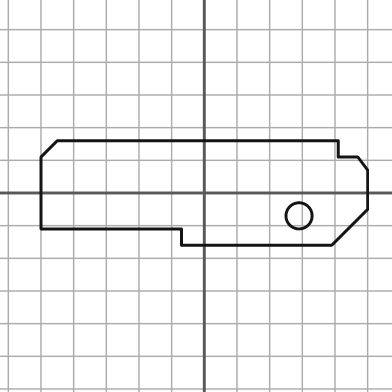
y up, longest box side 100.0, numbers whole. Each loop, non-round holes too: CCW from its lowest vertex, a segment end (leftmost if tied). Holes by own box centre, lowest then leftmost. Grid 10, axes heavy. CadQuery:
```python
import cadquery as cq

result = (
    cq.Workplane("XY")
    .moveTo(-7.0, -16.0)
    .lineTo(39.0, -16.0)
    .lineTo(50.0, -5.0)
    .lineTo(50.0, 7.0)
    .lineTo(47.0, 11.0)
    .lineTo(41.0, 11.0)
    .lineTo(41.0, 16.0)
    .lineTo(-45.0, 16.0)
    .lineTo(-50.0, 11.0)
    .lineTo(-50.0, -11.0)
    .lineTo(-7.0, -11.0)
    .close()
    .moveTo(29.0, -7.0)
    .circle(4.0)
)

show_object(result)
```